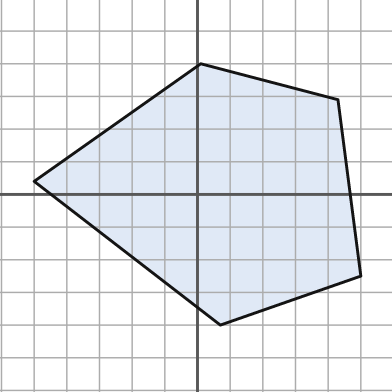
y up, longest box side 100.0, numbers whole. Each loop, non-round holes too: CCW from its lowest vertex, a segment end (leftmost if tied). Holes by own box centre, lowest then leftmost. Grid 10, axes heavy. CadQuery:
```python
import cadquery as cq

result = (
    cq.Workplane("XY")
    .moveTo(7.0, -40.0)
    .lineTo(50.0, -25.0)
    .lineTo(43.0, 29.0)
    .lineTo(1.0, 40.0)
    .lineTo(-50.0, 4.0)
    .close()
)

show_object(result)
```